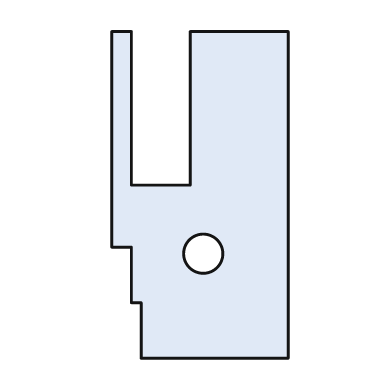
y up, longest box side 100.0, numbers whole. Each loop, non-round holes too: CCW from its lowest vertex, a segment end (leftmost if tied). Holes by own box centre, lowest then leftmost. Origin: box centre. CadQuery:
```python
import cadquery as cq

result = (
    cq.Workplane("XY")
    .moveTo(-18.0, -50.0)
    .lineTo(27.0, -50.0)
    .lineTo(27.0, 50.0)
    .lineTo(-3.0, 50.0)
    .lineTo(-3.0, 3.0)
    .lineTo(-21.0, 3.0)
    .lineTo(-21.0, 50.0)
    .lineTo(-27.0, 50.0)
    .lineTo(-27.0, -16.0)
    .lineTo(-21.0, -16.0)
    .lineTo(-21.0, -33.0)
    .lineTo(-18.0, -33.0)
    .close()
    .moveTo(1.0, -18.0)
    .circle(6.0)
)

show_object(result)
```